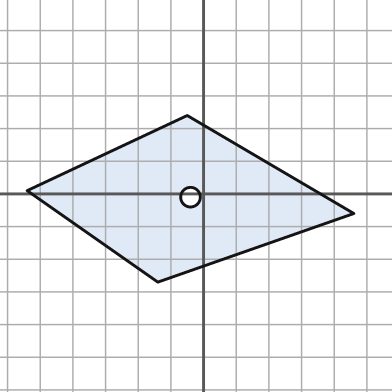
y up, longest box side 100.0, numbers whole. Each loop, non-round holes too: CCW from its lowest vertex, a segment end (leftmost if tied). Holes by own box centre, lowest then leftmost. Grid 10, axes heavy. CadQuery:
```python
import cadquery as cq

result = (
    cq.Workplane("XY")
    .moveTo(-14.0, -27.0)
    .lineTo(46.0, -6.0)
    .lineTo(-5.0, 24.0)
    .lineTo(-54.0, 1.0)
    .close()
    .moveTo(-4.0, -1.0)
    .circle(3.0)
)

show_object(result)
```